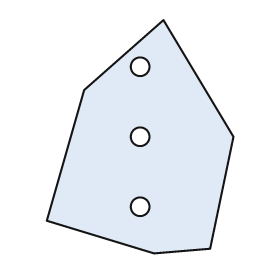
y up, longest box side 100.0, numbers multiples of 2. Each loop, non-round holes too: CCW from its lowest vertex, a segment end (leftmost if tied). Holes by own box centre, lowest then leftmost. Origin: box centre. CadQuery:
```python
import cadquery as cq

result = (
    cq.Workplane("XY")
    .moveTo(6.0, -50.0)
    .lineTo(30.0, -48.0)
    .lineTo(40.0, 0.0)
    .lineTo(10.0, 50.0)
    .lineTo(-24.0, 20.0)
    .lineTo(-40.0, -36.0)
    .close()
    .moveTo(0.0, -30.0)
    .circle(4.0)
    .moveTo(0.0, 0.0)
    .circle(4.0)
    .moveTo(0.0, 30.0)
    .circle(4.0)
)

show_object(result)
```